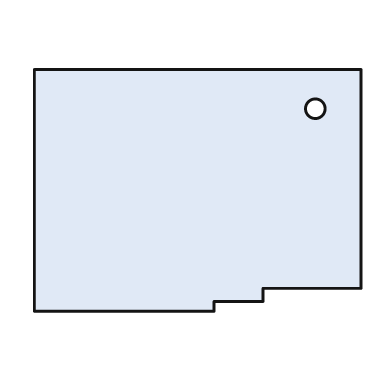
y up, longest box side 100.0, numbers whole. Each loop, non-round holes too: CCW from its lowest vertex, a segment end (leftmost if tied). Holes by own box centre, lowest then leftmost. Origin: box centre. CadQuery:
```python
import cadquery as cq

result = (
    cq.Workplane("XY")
    .moveTo(-50.0, -37.0)
    .lineTo(5.0, -37.0)
    .lineTo(5.0, -34.0)
    .lineTo(20.0, -34.0)
    .lineTo(20.0, -30.0)
    .lineTo(50.0, -30.0)
    .lineTo(50.0, 37.0)
    .lineTo(-50.0, 37.0)
    .close()
    .moveTo(36.0, 25.0)
    .circle(3.0)
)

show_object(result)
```